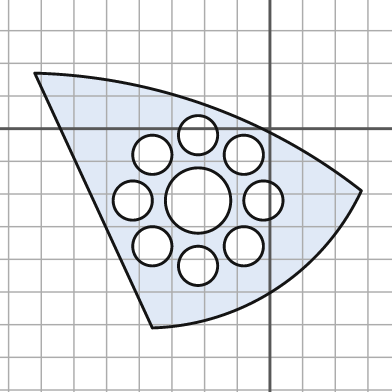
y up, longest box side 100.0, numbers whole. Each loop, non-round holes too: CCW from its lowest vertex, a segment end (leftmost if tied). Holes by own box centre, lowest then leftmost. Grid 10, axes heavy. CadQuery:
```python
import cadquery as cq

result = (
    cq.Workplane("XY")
    .moveTo(-36.0, -61.0)
    .threePointArc((2.0, -49.0), (28.0, -19.0))
    .threePointArc((-19.0, 7.0), (-72.0, 17.0))
    .close()
    .moveTo(-22.0, -42.0)
    .circle(6.0)
    .moveTo(-36.0, -36.0)
    .circle(6.0)
    .moveTo(-8.0, -36.0)
    .circle(6.0)
    .moveTo(-42.0, -22.0)
    .circle(6.0)
    .moveTo(-22.0, -22.0)
    .circle(10.0)
    .moveTo(-2.0, -22.0)
    .circle(6.0)
    .moveTo(-36.0, -8.0)
    .circle(6.0)
    .moveTo(-8.0, -8.0)
    .circle(6.0)
    .moveTo(-22.0, -2.0)
    .circle(6.0)
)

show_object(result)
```